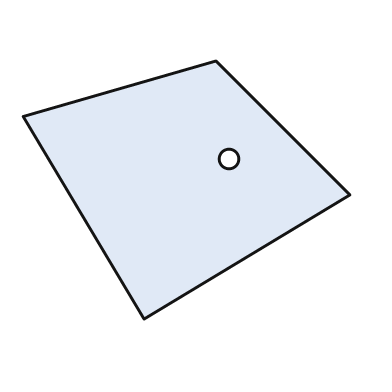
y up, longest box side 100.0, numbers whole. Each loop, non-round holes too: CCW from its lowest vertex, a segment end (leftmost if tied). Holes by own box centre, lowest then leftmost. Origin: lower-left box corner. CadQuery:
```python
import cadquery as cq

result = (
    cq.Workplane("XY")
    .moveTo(37.0, 0.0)
    .lineTo(100.0, 38.0)
    .lineTo(59.0, 79.0)
    .lineTo(0.0, 62.0)
    .close()
    .moveTo(63.0, 49.0)
    .circle(3.0)
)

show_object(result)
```